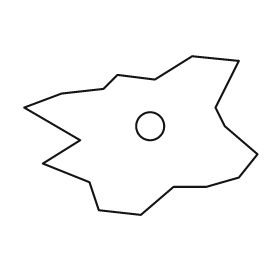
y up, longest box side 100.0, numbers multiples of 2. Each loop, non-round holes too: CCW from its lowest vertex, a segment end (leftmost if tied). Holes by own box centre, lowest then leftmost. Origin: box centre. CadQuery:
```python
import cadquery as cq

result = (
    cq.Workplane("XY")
    .moveTo(0.0, -34.0)
    .lineTo(14.0, -22.0)
    .lineTo(28.0, -22.0)
    .lineTo(42.0, -18.0)
    .lineTo(50.0, -8.0)
    .lineTo(36.0, 4.0)
    .lineTo(32.0, 12.0)
    .lineTo(42.0, 32.0)
    .lineTo(22.0, 34.0)
    .lineTo(6.0, 24.0)
    .lineTo(-10.0, 26.0)
    .lineTo(-16.0, 20.0)
    .lineTo(-34.0, 18.0)
    .lineTo(-50.0, 12.0)
    .lineTo(-26.0, -2.0)
    .lineTo(-42.0, -12.0)
    .lineTo(-22.0, -20.0)
    .lineTo(-18.0, -32.0)
    .close()
    .moveTo(4.0, 4.0)
    .circle(6.0)
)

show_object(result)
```